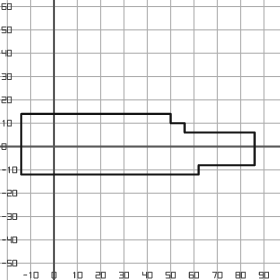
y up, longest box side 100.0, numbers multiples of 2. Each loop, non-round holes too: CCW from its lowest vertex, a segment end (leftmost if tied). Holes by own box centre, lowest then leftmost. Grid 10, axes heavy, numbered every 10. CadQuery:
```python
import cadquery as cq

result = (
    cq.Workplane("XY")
    .moveTo(-14.0, -12.0)
    .lineTo(62.0, -12.0)
    .lineTo(62.0, -8.0)
    .lineTo(86.0, -8.0)
    .lineTo(86.0, 6.0)
    .lineTo(56.0, 6.0)
    .lineTo(56.0, 10.0)
    .lineTo(50.0, 10.0)
    .lineTo(50.0, 14.0)
    .lineTo(-14.0, 14.0)
    .close()
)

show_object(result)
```